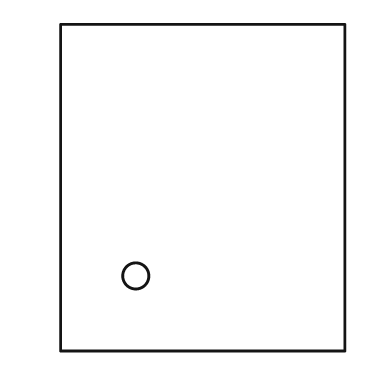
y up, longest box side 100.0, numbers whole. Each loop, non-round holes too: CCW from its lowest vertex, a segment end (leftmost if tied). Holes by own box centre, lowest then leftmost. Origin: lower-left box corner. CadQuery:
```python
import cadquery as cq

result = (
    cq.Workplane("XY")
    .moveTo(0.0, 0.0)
    .lineTo(87.0, 0.0)
    .lineTo(87.0, 100.0)
    .lineTo(0.0, 100.0)
    .close()
    .moveTo(23.0, 23.0)
    .circle(4.0)
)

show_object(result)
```